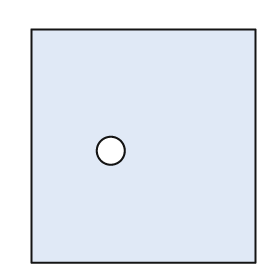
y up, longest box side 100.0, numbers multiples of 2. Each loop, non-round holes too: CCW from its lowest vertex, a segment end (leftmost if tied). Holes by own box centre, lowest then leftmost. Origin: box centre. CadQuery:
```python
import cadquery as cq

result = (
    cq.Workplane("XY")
    .moveTo(-48.0, -50.0)
    .lineTo(48.0, -50.0)
    .lineTo(48.0, 50.0)
    .lineTo(-48.0, 50.0)
    .close()
    .moveTo(-14.0, -2.0)
    .circle(6.0)
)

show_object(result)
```